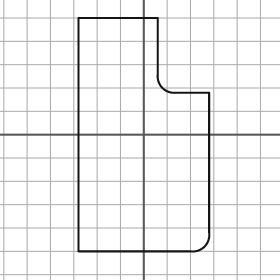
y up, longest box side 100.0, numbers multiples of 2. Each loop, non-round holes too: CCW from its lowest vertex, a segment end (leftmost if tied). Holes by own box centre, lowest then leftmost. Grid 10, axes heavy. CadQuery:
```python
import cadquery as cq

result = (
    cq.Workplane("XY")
    .moveTo(-28.0, -50.0)
    .lineTo(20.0, -50.0)
    .threePointArc((26.0, -48.0), (28.0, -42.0))
    .lineTo(28.0, 18.0)
    .lineTo(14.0, 18.0)
    .threePointArc((8.0, 20.0), (6.0, 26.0))
    .lineTo(6.0, 50.0)
    .lineTo(-28.0, 50.0)
    .close()
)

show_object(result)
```